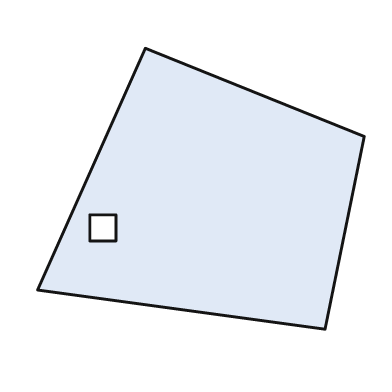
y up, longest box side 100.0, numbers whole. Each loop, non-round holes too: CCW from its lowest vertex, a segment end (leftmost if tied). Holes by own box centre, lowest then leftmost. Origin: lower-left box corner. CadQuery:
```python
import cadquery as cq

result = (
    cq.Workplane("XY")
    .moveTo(88.0, 0.0)
    .lineTo(100.0, 59.0)
    .lineTo(33.0, 86.0)
    .lineTo(0.0, 12.0)
    .close()
    .moveTo(16.0, 27.0)
    .lineTo(24.0, 27.0)
    .lineTo(24.0, 35.0)
    .lineTo(16.0, 35.0)
    .close()
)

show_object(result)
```